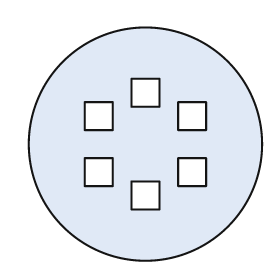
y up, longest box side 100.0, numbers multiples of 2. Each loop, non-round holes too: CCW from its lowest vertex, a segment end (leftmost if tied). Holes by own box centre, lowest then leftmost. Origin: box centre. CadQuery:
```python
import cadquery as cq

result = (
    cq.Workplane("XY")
    .moveTo(0.0, 0.0)
    .circle(50.0)
    .moveTo(-6.0, -28.0)
    .lineTo(6.0, -28.0)
    .lineTo(6.0, -16.0)
    .lineTo(-6.0, -16.0)
    .close()
    .moveTo(-26.0, -18.0)
    .lineTo(-14.0, -18.0)
    .lineTo(-14.0, -6.0)
    .lineTo(-26.0, -6.0)
    .close()
    .moveTo(14.0, -18.0)
    .lineTo(26.0, -18.0)
    .lineTo(26.0, -6.0)
    .lineTo(14.0, -6.0)
    .close()
    .moveTo(-26.0, 6.0)
    .lineTo(-14.0, 6.0)
    .lineTo(-14.0, 18.0)
    .lineTo(-26.0, 18.0)
    .close()
    .moveTo(14.0, 6.0)
    .lineTo(26.0, 6.0)
    .lineTo(26.0, 18.0)
    .lineTo(14.0, 18.0)
    .close()
    .moveTo(-6.0, 16.0)
    .lineTo(6.0, 16.0)
    .lineTo(6.0, 28.0)
    .lineTo(-6.0, 28.0)
    .close()
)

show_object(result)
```